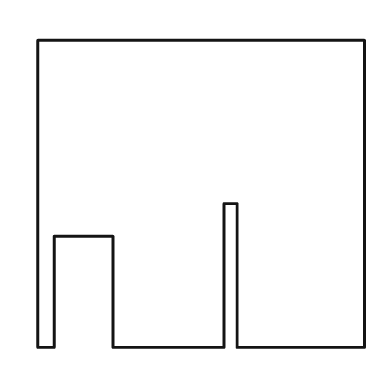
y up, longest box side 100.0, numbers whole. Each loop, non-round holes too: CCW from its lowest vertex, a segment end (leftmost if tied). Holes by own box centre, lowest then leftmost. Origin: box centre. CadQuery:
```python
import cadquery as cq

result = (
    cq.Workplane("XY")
    .moveTo(-50.0, -47.0)
    .lineTo(-45.0, -47.0)
    .lineTo(-45.0, -13.0)
    .lineTo(-27.0, -13.0)
    .lineTo(-27.0, -47.0)
    .lineTo(7.0, -47.0)
    .lineTo(7.0, -3.0)
    .lineTo(11.0, -3.0)
    .lineTo(11.0, -47.0)
    .lineTo(50.0, -47.0)
    .lineTo(50.0, 47.0)
    .lineTo(-50.0, 47.0)
    .close()
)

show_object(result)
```